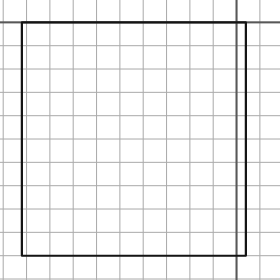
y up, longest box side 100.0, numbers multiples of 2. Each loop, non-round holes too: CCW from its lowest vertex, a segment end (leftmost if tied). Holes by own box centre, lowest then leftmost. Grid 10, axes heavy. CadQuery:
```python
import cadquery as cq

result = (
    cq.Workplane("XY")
    .moveTo(-92.0, -100.0)
    .lineTo(4.0, -100.0)
    .lineTo(4.0, 0.0)
    .lineTo(-92.0, 0.0)
    .close()
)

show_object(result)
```